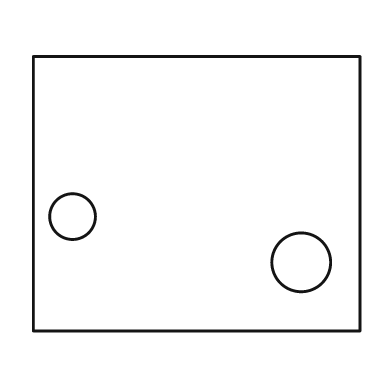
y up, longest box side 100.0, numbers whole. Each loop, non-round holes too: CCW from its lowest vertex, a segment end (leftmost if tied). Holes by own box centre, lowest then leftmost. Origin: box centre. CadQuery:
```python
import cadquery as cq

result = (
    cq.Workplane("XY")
    .moveTo(-50.0, -42.0)
    .lineTo(50.0, -42.0)
    .lineTo(50.0, 42.0)
    .lineTo(-50.0, 42.0)
    .close()
    .moveTo(32.0, -21.0)
    .circle(9.0)
    .moveTo(-38.0, -7.0)
    .circle(7.0)
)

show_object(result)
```